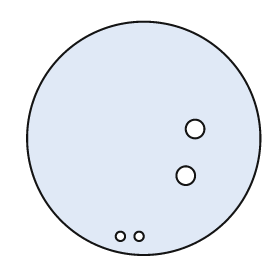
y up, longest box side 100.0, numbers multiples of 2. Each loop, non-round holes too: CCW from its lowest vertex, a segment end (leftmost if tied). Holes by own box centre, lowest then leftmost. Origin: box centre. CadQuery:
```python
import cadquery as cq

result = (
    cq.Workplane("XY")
    .moveTo(0.0, 0.0)
    .circle(50.0)
    .moveTo(-10.0, -42.0)
    .circle(2.0)
    .moveTo(-2.0, -42.0)
    .circle(2.0)
    .moveTo(18.0, -16.0)
    .circle(4.0)
    .moveTo(22.0, 4.0)
    .circle(4.0)
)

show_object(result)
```